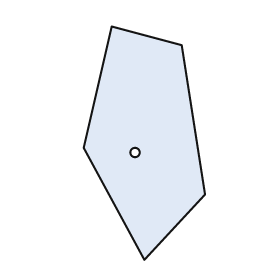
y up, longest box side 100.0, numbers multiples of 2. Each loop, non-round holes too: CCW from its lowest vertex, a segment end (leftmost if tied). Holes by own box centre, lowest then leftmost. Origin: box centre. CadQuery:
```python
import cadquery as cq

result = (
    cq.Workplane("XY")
    .moveTo(0.0, -50.0)
    .lineTo(26.0, -22.0)
    .lineTo(16.0, 42.0)
    .lineTo(-14.0, 50.0)
    .lineTo(-26.0, -2.0)
    .close()
    .moveTo(-4.0, -4.0)
    .circle(2.0)
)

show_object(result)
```